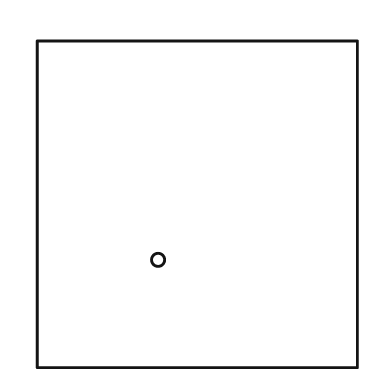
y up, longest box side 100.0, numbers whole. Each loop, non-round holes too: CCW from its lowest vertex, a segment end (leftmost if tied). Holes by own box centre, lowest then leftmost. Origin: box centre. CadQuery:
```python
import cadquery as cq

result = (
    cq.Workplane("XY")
    .moveTo(-49.0, -50.0)
    .lineTo(49.0, -50.0)
    .lineTo(49.0, 50.0)
    .lineTo(-49.0, 50.0)
    .close()
    .moveTo(-12.0, -17.0)
    .circle(2.0)
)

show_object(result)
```